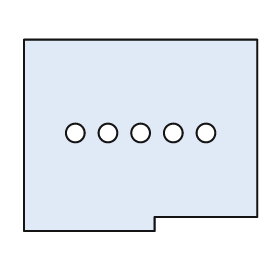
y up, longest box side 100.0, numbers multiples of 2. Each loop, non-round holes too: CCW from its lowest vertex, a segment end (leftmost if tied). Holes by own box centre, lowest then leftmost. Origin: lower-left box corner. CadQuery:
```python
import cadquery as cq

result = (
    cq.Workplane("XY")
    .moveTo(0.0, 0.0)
    .lineTo(56.0, 0.0)
    .lineTo(56.0, 6.0)
    .lineTo(100.0, 6.0)
    .lineTo(100.0, 82.0)
    .lineTo(0.0, 82.0)
    .close()
    .moveTo(22.0, 42.0)
    .circle(4.0)
    .moveTo(36.0, 42.0)
    .circle(4.0)
    .moveTo(50.0, 42.0)
    .circle(4.0)
    .moveTo(64.0, 42.0)
    .circle(4.0)
    .moveTo(78.0, 42.0)
    .circle(4.0)
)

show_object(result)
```